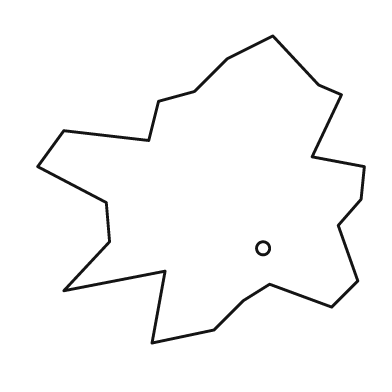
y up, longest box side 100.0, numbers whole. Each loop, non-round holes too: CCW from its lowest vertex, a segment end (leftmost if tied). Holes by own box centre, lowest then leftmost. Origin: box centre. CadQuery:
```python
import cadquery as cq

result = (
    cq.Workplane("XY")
    .moveTo(-15.0, -47.0)
    .lineTo(4.0, -43.0)
    .lineTo(13.0, -34.0)
    .lineTo(21.0, -29.0)
    .lineTo(40.0, -36.0)
    .lineTo(48.0, -28.0)
    .lineTo(42.0, -11.0)
    .lineTo(49.0, -3.0)
    .lineTo(50.0, 7.0)
    .lineTo(34.0, 10.0)
    .lineTo(43.0, 29.0)
    .lineTo(36.0, 32.0)
    .lineTo(22.0, 47.0)
    .lineTo(8.0, 40.0)
    .lineTo(-2.0, 30.0)
    .lineTo(-13.0, 27.0)
    .lineTo(-16.0, 15.0)
    .lineTo(-42.0, 18.0)
    .lineTo(-50.0, 7.0)
    .lineTo(-29.0, -4.0)
    .lineTo(-28.0, -16.0)
    .lineTo(-42.0, -31.0)
    .lineTo(-11.0, -25.0)
    .close()
    .moveTo(19.0, -18.0)
    .circle(2.0)
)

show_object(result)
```